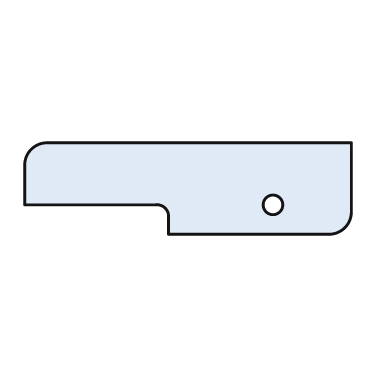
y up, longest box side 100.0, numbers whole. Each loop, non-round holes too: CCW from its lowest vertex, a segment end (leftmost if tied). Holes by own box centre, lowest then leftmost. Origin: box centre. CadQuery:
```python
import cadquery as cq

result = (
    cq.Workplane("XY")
    .moveTo(-6.0, -14.0)
    .lineTo(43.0, -14.0)
    .threePointArc((48.0, -12.0), (50.0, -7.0))
    .lineTo(50.0, 14.0)
    .lineTo(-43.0, 14.0)
    .threePointArc((-48.0, 12.0), (-50.0, 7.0))
    .lineTo(-50.0, -5.0)
    .lineTo(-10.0, -5.0)
    .threePointArc((-7.0, -6.0), (-6.0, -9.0))
    .close()
    .moveTo(26.0, -5.0)
    .circle(3.0)
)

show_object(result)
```